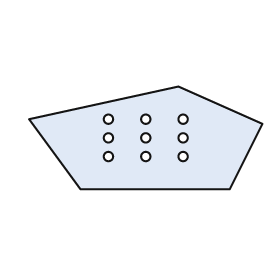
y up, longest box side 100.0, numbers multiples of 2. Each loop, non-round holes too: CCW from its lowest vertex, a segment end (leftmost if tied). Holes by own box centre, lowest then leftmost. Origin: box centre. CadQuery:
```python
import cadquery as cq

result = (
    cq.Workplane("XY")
    .moveTo(-28.0, -22.0)
    .lineTo(36.0, -22.0)
    .lineTo(50.0, 6.0)
    .lineTo(14.0, 22.0)
    .lineTo(-50.0, 8.0)
    .close()
    .moveTo(-16.0, -8.0)
    .circle(2.0)
    .moveTo(0.0, -8.0)
    .circle(2.0)
    .moveTo(16.0, -8.0)
    .circle(2.0)
    .moveTo(-16.0, 0.0)
    .circle(2.0)
    .moveTo(0.0, 0.0)
    .circle(2.0)
    .moveTo(16.0, 0.0)
    .circle(2.0)
    .moveTo(-16.0, 8.0)
    .circle(2.0)
    .moveTo(0.0, 8.0)
    .circle(2.0)
    .moveTo(16.0, 8.0)
    .circle(2.0)
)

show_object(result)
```